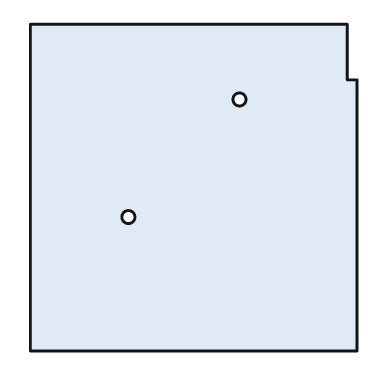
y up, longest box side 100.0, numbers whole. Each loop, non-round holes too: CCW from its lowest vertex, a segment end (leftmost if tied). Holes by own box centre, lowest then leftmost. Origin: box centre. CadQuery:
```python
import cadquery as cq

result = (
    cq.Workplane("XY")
    .moveTo(-50.0, -50.0)
    .lineTo(50.0, -50.0)
    .lineTo(50.0, 33.0)
    .lineTo(47.0, 33.0)
    .lineTo(47.0, 50.0)
    .lineTo(-50.0, 50.0)
    .close()
    .moveTo(-20.0, -9.0)
    .circle(2.0)
    .moveTo(14.0, 27.0)
    .circle(2.0)
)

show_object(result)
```